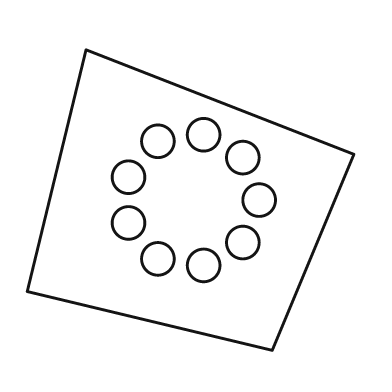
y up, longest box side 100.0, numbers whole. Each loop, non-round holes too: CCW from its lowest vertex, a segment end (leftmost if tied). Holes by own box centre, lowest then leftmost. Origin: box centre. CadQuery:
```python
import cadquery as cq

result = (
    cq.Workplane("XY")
    .moveTo(25.0, -46.0)
    .lineTo(50.0, 14.0)
    .lineTo(-32.0, 46.0)
    .lineTo(-50.0, -28.0)
    .close()
    .moveTo(4.0, -20.0)
    .circle(5.0)
    .moveTo(-10.0, -18.0)
    .circle(5.0)
    .moveTo(16.0, -13.0)
    .circle(5.0)
    .moveTo(-19.0, -7.0)
    .circle(5.0)
    .moveTo(21.0, 0.0)
    .circle(5.0)
    .moveTo(-19.0, 7.0)
    .circle(5.0)
    .moveTo(16.0, 13.0)
    .circle(5.0)
    .moveTo(-10.0, 18.0)
    .circle(5.0)
    .moveTo(4.0, 20.0)
    .circle(5.0)
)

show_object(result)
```